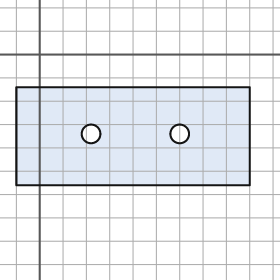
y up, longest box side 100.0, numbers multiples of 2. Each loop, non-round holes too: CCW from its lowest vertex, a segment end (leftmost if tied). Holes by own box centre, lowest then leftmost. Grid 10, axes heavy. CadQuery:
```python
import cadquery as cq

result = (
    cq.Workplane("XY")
    .moveTo(-10.0, -56.0)
    .lineTo(90.0, -56.0)
    .lineTo(90.0, -14.0)
    .lineTo(-10.0, -14.0)
    .close()
    .moveTo(22.0, -34.0)
    .circle(4.0)
    .moveTo(60.0, -34.0)
    .circle(4.0)
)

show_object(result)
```